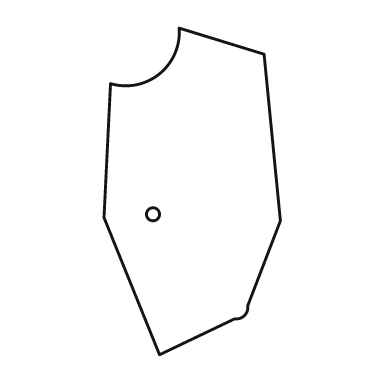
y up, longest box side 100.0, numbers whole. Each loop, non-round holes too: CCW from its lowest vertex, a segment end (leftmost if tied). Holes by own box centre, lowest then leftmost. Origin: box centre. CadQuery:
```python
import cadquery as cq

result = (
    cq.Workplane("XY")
    .moveTo(-10.0, -50.0)
    .lineTo(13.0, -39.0)
    .threePointArc((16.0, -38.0), (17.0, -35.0))
    .lineTo(27.0, -9.0)
    .lineTo(22.0, 42.0)
    .lineTo(-4.0, 50.0)
    .threePointArc((-10.0, 36.0), (-25.0, 33.0))
    .lineTo(-27.0, -8.0)
    .close()
    .moveTo(-12.0, -7.0)
    .circle(2.0)
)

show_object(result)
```